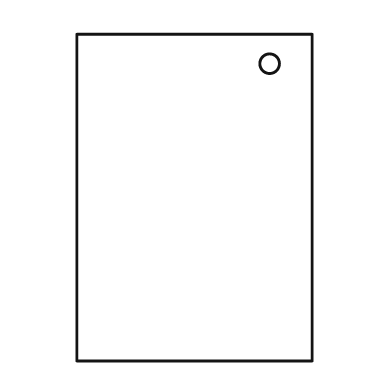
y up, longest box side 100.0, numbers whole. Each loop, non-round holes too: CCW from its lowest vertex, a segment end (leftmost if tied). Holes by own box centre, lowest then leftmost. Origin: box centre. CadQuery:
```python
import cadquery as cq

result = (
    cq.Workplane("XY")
    .moveTo(-36.0, -50.0)
    .lineTo(36.0, -50.0)
    .lineTo(36.0, 50.0)
    .lineTo(-36.0, 50.0)
    .close()
    .moveTo(23.0, 41.0)
    .circle(3.0)
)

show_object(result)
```